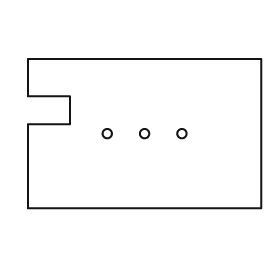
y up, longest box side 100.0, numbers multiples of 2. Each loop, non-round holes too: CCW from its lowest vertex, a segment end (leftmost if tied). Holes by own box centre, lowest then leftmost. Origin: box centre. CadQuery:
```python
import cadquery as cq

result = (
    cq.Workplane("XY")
    .moveTo(-50.0, -32.0)
    .lineTo(50.0, -32.0)
    .lineTo(50.0, 32.0)
    .lineTo(-50.0, 32.0)
    .lineTo(-50.0, 16.0)
    .lineTo(-32.0, 16.0)
    .lineTo(-32.0, 4.0)
    .lineTo(-50.0, 4.0)
    .close()
    .moveTo(-16.0, 0.0)
    .circle(2.0)
    .moveTo(0.0, 0.0)
    .circle(2.0)
    .moveTo(16.0, 0.0)
    .circle(2.0)
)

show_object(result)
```